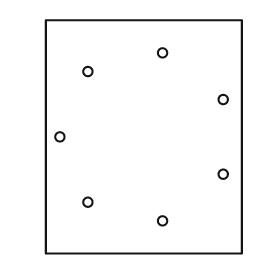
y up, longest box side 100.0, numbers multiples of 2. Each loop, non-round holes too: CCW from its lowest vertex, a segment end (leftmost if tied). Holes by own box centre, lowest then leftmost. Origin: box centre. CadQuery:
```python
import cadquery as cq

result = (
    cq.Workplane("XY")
    .moveTo(-42.0, -50.0)
    .lineTo(42.0, -50.0)
    .lineTo(42.0, 50.0)
    .lineTo(-42.0, 50.0)
    .close()
    .moveTo(8.0, -36.0)
    .circle(2.0)
    .moveTo(-24.0, -28.0)
    .circle(2.0)
    .moveTo(34.0, -16.0)
    .circle(2.0)
    .moveTo(-36.0, 0.0)
    .circle(2.0)
    .moveTo(34.0, 16.0)
    .circle(2.0)
    .moveTo(-24.0, 28.0)
    .circle(2.0)
    .moveTo(8.0, 36.0)
    .circle(2.0)
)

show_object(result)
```